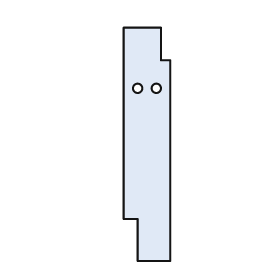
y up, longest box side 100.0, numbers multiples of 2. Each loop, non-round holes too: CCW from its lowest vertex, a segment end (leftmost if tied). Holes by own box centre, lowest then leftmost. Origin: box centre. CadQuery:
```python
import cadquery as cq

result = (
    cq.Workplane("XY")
    .moveTo(-4.0, -50.0)
    .lineTo(10.0, -50.0)
    .lineTo(10.0, 36.0)
    .lineTo(6.0, 36.0)
    .lineTo(6.0, 50.0)
    .lineTo(-10.0, 50.0)
    .lineTo(-10.0, -32.0)
    .lineTo(-4.0, -32.0)
    .close()
    .moveTo(-4.0, 24.0)
    .circle(2.0)
    .moveTo(4.0, 24.0)
    .circle(2.0)
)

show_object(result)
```